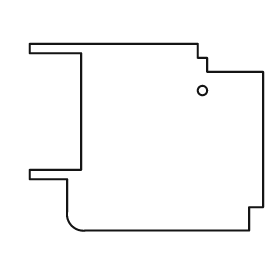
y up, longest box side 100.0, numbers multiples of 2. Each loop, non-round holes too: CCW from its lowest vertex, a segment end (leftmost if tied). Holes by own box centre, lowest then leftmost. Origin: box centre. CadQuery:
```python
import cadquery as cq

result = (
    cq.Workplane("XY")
    .moveTo(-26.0, -40.0)
    .lineTo(44.0, -40.0)
    .lineTo(44.0, -30.0)
    .lineTo(50.0, -30.0)
    .lineTo(50.0, 28.0)
    .lineTo(26.0, 28.0)
    .lineTo(26.0, 34.0)
    .lineTo(22.0, 34.0)
    .lineTo(22.0, 40.0)
    .lineTo(-50.0, 40.0)
    .lineTo(-50.0, 36.0)
    .lineTo(-28.0, 36.0)
    .lineTo(-28.0, -14.0)
    .lineTo(-50.0, -14.0)
    .lineTo(-50.0, -18.0)
    .lineTo(-34.0, -18.0)
    .lineTo(-34.0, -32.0)
    .threePointArc((-32.0, -38.0), (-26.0, -40.0))
    .close()
    .moveTo(24.0, 20.0)
    .circle(2.0)
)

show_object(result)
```